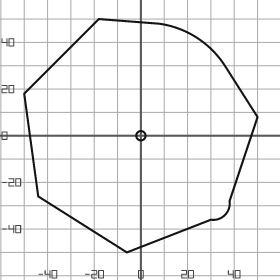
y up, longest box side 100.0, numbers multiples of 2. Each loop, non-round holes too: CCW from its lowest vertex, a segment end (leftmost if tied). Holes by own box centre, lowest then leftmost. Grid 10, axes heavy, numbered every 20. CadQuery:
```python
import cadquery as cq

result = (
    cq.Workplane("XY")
    .moveTo(-6.0, -50.0)
    .lineTo(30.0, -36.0)
    .threePointArc((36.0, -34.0), (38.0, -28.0))
    .lineTo(50.0, 8.0)
    .lineTo(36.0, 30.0)
    .threePointArc((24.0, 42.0), (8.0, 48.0))
    .lineTo(-18.0, 50.0)
    .lineTo(-50.0, 18.0)
    .lineTo(-44.0, -26.0)
    .close()
    .moveTo(0.0, 0.0)
    .circle(2.0)
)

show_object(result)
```